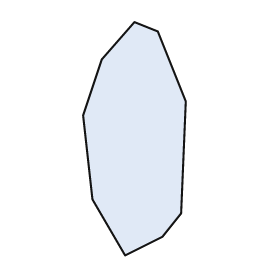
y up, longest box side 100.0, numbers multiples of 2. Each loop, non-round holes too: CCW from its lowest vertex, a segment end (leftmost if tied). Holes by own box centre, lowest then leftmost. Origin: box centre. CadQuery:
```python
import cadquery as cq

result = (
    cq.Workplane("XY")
    .moveTo(-4.0, -50.0)
    .lineTo(12.0, -42.0)
    .lineTo(20.0, -32.0)
    .lineTo(22.0, 16.0)
    .lineTo(10.0, 46.0)
    .lineTo(0.0, 50.0)
    .lineTo(-14.0, 34.0)
    .lineTo(-22.0, 10.0)
    .lineTo(-18.0, -26.0)
    .close()
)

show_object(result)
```